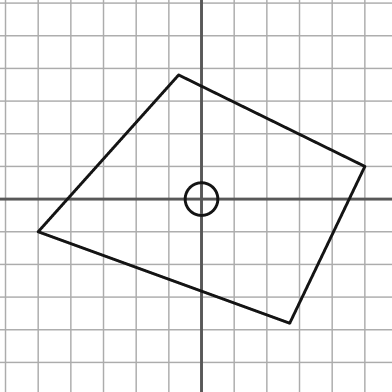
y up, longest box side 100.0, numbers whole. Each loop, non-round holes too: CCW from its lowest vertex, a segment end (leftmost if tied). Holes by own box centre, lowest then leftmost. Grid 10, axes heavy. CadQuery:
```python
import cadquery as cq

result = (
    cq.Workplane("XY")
    .moveTo(27.0, -38.0)
    .lineTo(50.0, 10.0)
    .lineTo(-7.0, 38.0)
    .lineTo(-50.0, -10.0)
    .close()
    .moveTo(0.0, 0.0)
    .circle(5.0)
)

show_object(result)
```